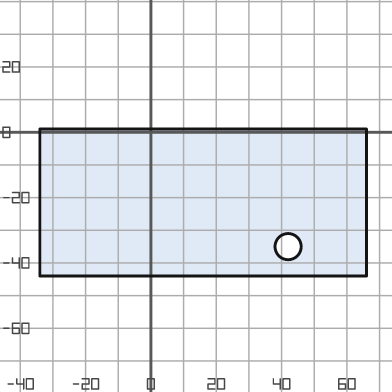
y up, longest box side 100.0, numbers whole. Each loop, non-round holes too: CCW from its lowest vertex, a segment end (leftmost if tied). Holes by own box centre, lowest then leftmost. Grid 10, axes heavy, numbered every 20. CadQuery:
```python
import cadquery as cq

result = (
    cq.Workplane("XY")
    .moveTo(-34.0, -44.0)
    .lineTo(66.0, -44.0)
    .lineTo(66.0, 1.0)
    .lineTo(-34.0, 1.0)
    .close()
    .moveTo(42.0, -35.0)
    .circle(4.0)
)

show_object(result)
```